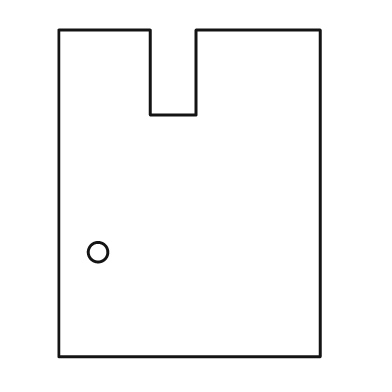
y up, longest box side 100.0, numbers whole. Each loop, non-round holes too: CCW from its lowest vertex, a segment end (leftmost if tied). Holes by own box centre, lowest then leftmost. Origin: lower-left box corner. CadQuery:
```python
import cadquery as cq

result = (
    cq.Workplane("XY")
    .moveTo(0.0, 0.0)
    .lineTo(80.0, 0.0)
    .lineTo(80.0, 100.0)
    .lineTo(42.0, 100.0)
    .lineTo(42.0, 74.0)
    .lineTo(28.0, 74.0)
    .lineTo(28.0, 100.0)
    .lineTo(0.0, 100.0)
    .close()
    .moveTo(12.0, 32.0)
    .circle(3.0)
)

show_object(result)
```